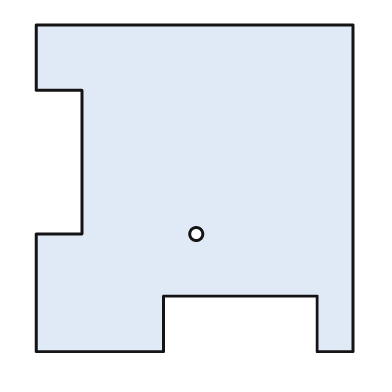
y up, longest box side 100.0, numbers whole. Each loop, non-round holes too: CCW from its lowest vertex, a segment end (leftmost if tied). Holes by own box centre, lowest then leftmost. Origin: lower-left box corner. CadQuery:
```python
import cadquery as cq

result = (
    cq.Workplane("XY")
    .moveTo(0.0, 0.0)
    .lineTo(39.0, 0.0)
    .lineTo(39.0, 17.0)
    .lineTo(86.0, 17.0)
    .lineTo(86.0, 0.0)
    .lineTo(97.0, 0.0)
    .lineTo(97.0, 100.0)
    .lineTo(0.0, 100.0)
    .lineTo(0.0, 80.0)
    .lineTo(14.0, 80.0)
    .lineTo(14.0, 36.0)
    .lineTo(0.0, 36.0)
    .close()
    .moveTo(49.0, 36.0)
    .circle(2.0)
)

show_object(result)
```